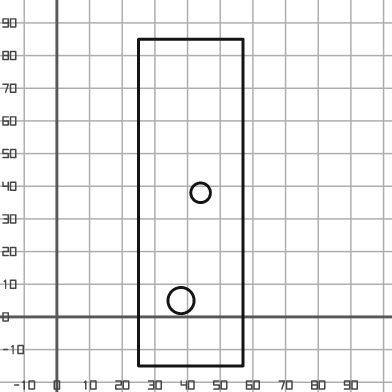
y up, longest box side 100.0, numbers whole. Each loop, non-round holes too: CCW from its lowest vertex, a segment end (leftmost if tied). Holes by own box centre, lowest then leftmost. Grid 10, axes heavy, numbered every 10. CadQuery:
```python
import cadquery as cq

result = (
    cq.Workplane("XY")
    .moveTo(25.0, -15.0)
    .lineTo(57.0, -15.0)
    .lineTo(57.0, 85.0)
    .lineTo(25.0, 85.0)
    .close()
    .moveTo(38.0, 5.0)
    .circle(4.0)
    .moveTo(44.0, 38.0)
    .circle(3.0)
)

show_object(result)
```